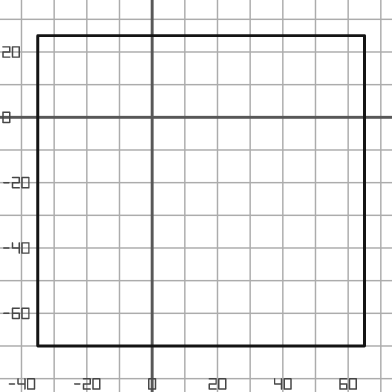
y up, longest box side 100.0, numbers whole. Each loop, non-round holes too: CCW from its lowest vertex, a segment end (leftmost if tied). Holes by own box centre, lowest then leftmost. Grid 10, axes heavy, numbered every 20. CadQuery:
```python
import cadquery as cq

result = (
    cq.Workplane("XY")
    .moveTo(-35.0, -70.0)
    .lineTo(65.0, -70.0)
    .lineTo(65.0, 25.0)
    .lineTo(-35.0, 25.0)
    .close()
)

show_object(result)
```